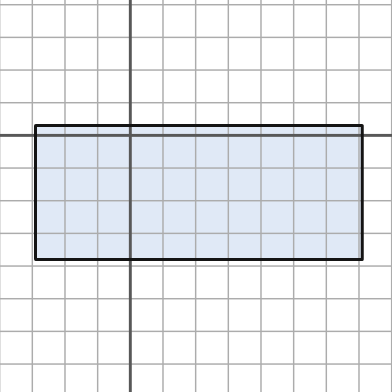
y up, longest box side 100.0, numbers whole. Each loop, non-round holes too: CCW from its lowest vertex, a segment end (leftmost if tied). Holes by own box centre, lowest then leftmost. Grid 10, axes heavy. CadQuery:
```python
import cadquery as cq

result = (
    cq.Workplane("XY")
    .moveTo(-29.0, -38.0)
    .lineTo(71.0, -38.0)
    .lineTo(71.0, 3.0)
    .lineTo(-29.0, 3.0)
    .close()
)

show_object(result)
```